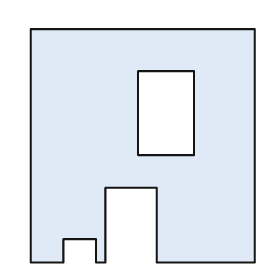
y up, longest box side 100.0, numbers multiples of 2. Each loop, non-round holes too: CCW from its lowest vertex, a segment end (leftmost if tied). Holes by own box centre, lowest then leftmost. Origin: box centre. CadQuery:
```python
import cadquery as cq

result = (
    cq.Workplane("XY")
    .moveTo(-48.0, -50.0)
    .lineTo(-34.0, -50.0)
    .lineTo(-34.0, -40.0)
    .lineTo(-20.0, -40.0)
    .lineTo(-20.0, -50.0)
    .lineTo(-16.0, -50.0)
    .lineTo(-16.0, -18.0)
    .lineTo(6.0, -18.0)
    .lineTo(6.0, -50.0)
    .lineTo(48.0, -50.0)
    .lineTo(48.0, 50.0)
    .lineTo(-48.0, 50.0)
    .close()
    .moveTo(-2.0, -4.0)
    .lineTo(22.0, -4.0)
    .lineTo(22.0, 32.0)
    .lineTo(-2.0, 32.0)
    .close()
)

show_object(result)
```